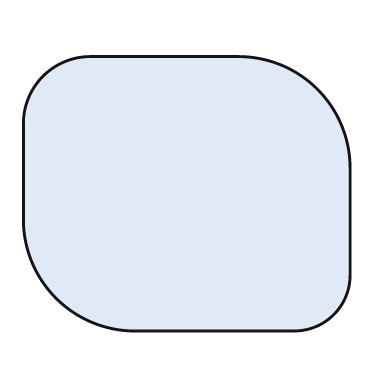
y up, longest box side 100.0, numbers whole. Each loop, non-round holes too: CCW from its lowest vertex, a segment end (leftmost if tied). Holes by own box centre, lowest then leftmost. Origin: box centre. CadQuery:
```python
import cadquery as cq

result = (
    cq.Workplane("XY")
    .moveTo(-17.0, -42.0)
    .lineTo(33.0, -42.0)
    .threePointArc((45.0, -37.0), (50.0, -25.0))
    .lineTo(50.0, 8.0)
    .threePointArc((40.0, 32.0), (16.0, 42.0))
    .lineTo(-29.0, 42.0)
    .threePointArc((-44.0, 36.0), (-50.0, 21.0))
    .lineTo(-50.0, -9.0)
    .threePointArc((-40.0, -32.0), (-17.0, -42.0))
    .close()
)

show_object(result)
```